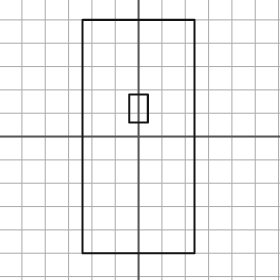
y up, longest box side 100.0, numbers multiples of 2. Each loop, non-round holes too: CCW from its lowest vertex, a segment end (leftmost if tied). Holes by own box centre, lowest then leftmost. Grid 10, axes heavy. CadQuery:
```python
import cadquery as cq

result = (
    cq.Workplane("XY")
    .moveTo(-24.0, -50.0)
    .lineTo(24.0, -50.0)
    .lineTo(24.0, 50.0)
    .lineTo(-24.0, 50.0)
    .close()
    .moveTo(-4.0, 6.0)
    .lineTo(4.0, 6.0)
    .lineTo(4.0, 18.0)
    .lineTo(-4.0, 18.0)
    .close()
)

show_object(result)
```